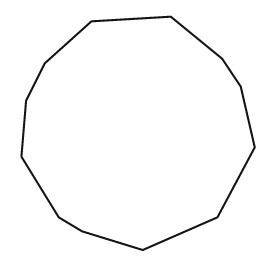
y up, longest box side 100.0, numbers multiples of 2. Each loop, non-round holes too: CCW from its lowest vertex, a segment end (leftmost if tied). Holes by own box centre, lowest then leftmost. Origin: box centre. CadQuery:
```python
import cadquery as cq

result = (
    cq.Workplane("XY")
    .moveTo(2.0, -50.0)
    .lineTo(34.0, -36.0)
    .lineTo(50.0, -6.0)
    .lineTo(44.0, 20.0)
    .lineTo(36.0, 32.0)
    .lineTo(14.0, 50.0)
    .lineTo(-20.0, 48.0)
    .lineTo(-40.0, 30.0)
    .lineTo(-48.0, 14.0)
    .lineTo(-50.0, -10.0)
    .lineTo(-34.0, -36.0)
    .lineTo(-24.0, -42.0)
    .close()
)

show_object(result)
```